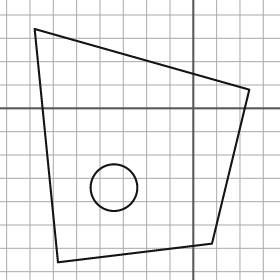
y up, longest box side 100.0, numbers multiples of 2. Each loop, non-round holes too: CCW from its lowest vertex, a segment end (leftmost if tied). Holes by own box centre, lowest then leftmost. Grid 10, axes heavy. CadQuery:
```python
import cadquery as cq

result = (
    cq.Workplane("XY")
    .moveTo(-58.0, -66.0)
    .lineTo(8.0, -58.0)
    .lineTo(24.0, 8.0)
    .lineTo(-68.0, 34.0)
    .close()
    .moveTo(-34.0, -34.0)
    .circle(10.0)
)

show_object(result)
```